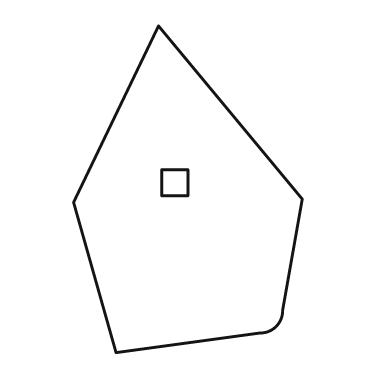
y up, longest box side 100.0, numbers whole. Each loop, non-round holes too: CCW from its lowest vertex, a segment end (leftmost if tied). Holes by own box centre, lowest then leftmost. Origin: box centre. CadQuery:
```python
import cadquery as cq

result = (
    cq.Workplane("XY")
    .moveTo(-22.0, -50.0)
    .lineTo(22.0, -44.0)
    .threePointArc((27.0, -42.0), (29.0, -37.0))
    .lineTo(35.0, -3.0)
    .lineTo(-9.0, 50.0)
    .lineTo(-35.0, -4.0)
    .close()
    .moveTo(-8.0, -2.0)
    .lineTo(0.0, -2.0)
    .lineTo(0.0, 6.0)
    .lineTo(-8.0, 6.0)
    .close()
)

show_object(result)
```